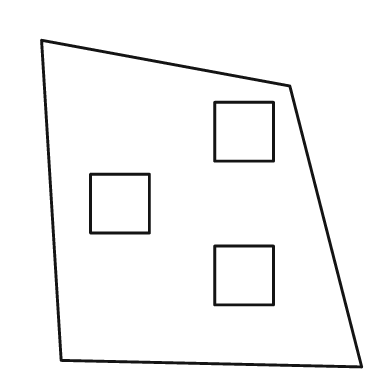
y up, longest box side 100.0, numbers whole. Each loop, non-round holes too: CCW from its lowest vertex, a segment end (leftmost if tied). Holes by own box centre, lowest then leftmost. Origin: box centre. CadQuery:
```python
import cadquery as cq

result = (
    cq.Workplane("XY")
    .moveTo(49.0, -50.0)
    .lineTo(27.0, 36.0)
    .lineTo(-49.0, 50.0)
    .lineTo(-43.0, -48.0)
    .close()
    .moveTo(4.0, -31.0)
    .lineTo(22.0, -31.0)
    .lineTo(22.0, -13.0)
    .lineTo(4.0, -13.0)
    .close()
    .moveTo(-34.0, -9.0)
    .lineTo(-16.0, -9.0)
    .lineTo(-16.0, 9.0)
    .lineTo(-34.0, 9.0)
    .close()
    .moveTo(4.0, 13.0)
    .lineTo(22.0, 13.0)
    .lineTo(22.0, 31.0)
    .lineTo(4.0, 31.0)
    .close()
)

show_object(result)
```